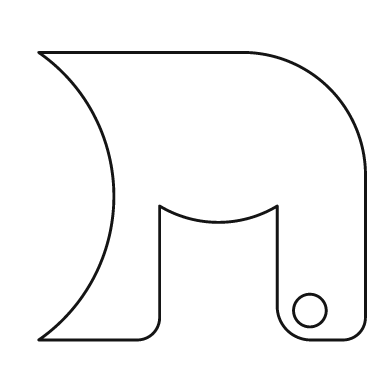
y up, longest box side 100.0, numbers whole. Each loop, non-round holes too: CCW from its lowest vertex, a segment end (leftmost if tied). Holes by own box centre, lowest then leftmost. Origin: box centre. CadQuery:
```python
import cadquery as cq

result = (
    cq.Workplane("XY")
    .moveTo(-50.0, -44.0)
    .lineTo(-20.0, -44.0)
    .threePointArc((-15.0, -42.0), (-13.0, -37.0))
    .lineTo(-13.0, -3.0)
    .threePointArc((5.0, -8.0), (23.0, -3.0))
    .lineTo(23.0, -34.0)
    .threePointArc((26.0, -41.0), (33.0, -44.0))
    .lineTo(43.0, -44.0)
    .threePointArc((48.0, -42.0), (50.0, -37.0))
    .lineTo(50.0, 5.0)
    .threePointArc((39.0, 33.0), (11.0, 44.0))
    .lineTo(-50.0, 44.0)
    .threePointArc((-27.0, 0.0), (-50.0, -44.0))
    .close()
    .moveTo(33.0, -35.0)
    .circle(5.0)
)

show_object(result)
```